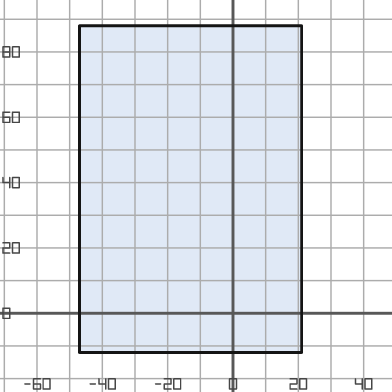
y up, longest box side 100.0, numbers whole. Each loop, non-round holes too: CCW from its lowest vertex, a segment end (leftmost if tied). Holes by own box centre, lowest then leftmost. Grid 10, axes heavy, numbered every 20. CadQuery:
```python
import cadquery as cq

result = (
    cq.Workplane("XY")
    .moveTo(-47.0, -12.0)
    .lineTo(21.0, -12.0)
    .lineTo(21.0, 88.0)
    .lineTo(-47.0, 88.0)
    .close()
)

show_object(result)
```